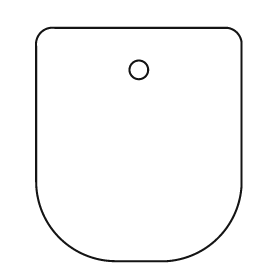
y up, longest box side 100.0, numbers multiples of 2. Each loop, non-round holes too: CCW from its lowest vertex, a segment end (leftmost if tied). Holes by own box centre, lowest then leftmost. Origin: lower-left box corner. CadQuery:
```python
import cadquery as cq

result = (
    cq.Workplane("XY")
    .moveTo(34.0, 0.0)
    .lineTo(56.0, 0.0)
    .threePointArc((78.0, 10.0), (88.0, 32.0))
    .lineTo(88.0, 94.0)
    .threePointArc((86.0, 98.0), (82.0, 100.0))
    .lineTo(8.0, 100.0)
    .threePointArc((2.0, 98.0), (0.0, 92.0))
    .lineTo(0.0, 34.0)
    .threePointArc((10.0, 10.0), (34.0, 0.0))
    .close()
    .moveTo(44.0, 82.0)
    .circle(4.0)
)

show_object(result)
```